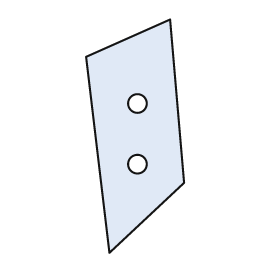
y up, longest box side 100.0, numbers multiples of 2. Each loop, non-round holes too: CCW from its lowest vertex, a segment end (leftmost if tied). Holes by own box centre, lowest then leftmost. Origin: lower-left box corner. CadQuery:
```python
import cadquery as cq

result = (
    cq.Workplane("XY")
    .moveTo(10.0, 0.0)
    .lineTo(42.0, 30.0)
    .lineTo(36.0, 100.0)
    .lineTo(0.0, 84.0)
    .close()
    .moveTo(22.0, 38.0)
    .circle(4.0)
    .moveTo(22.0, 64.0)
    .circle(4.0)
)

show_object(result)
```